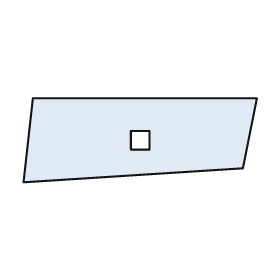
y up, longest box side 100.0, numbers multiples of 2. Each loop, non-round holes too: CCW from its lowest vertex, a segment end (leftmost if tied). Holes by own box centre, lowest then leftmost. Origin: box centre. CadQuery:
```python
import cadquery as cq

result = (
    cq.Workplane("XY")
    .moveTo(-50.0, -18.0)
    .lineTo(44.0, -12.0)
    .lineTo(50.0, 18.0)
    .lineTo(-46.0, 18.0)
    .close()
    .moveTo(-4.0, -4.0)
    .lineTo(4.0, -4.0)
    .lineTo(4.0, 4.0)
    .lineTo(-4.0, 4.0)
    .close()
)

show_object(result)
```